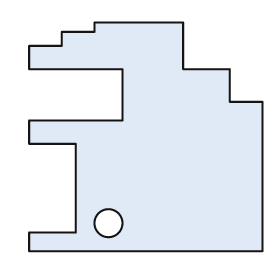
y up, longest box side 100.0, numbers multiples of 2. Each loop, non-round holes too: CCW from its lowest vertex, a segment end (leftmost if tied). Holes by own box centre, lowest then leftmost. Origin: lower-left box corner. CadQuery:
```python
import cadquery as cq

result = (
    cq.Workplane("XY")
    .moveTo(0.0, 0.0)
    .lineTo(100.0, 0.0)
    .lineTo(100.0, 64.0)
    .lineTo(86.0, 64.0)
    .lineTo(86.0, 78.0)
    .lineTo(66.0, 78.0)
    .lineTo(66.0, 98.0)
    .lineTo(28.0, 98.0)
    .lineTo(28.0, 94.0)
    .lineTo(14.0, 94.0)
    .lineTo(14.0, 88.0)
    .lineTo(0.0, 88.0)
    .lineTo(0.0, 78.0)
    .lineTo(40.0, 78.0)
    .lineTo(40.0, 56.0)
    .lineTo(0.0, 56.0)
    .lineTo(0.0, 46.0)
    .lineTo(20.0, 46.0)
    .lineTo(20.0, 8.0)
    .lineTo(0.0, 8.0)
    .close()
    .moveTo(34.0, 12.0)
    .circle(6.0)
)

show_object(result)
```